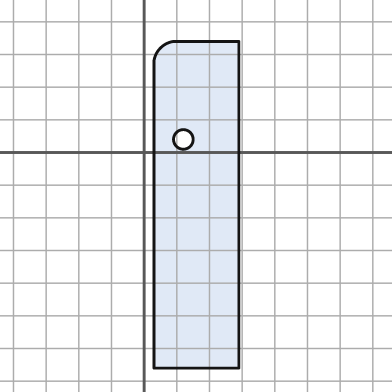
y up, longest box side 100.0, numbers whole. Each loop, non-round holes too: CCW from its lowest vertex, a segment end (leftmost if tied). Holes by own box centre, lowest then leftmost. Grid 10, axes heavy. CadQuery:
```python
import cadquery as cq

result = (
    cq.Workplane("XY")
    .moveTo(3.0, -66.0)
    .lineTo(29.0, -66.0)
    .lineTo(29.0, 34.0)
    .lineTo(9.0, 34.0)
    .threePointArc((5.0, 32.0), (3.0, 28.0))
    .close()
    .moveTo(12.0, 4.0)
    .circle(3.0)
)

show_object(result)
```